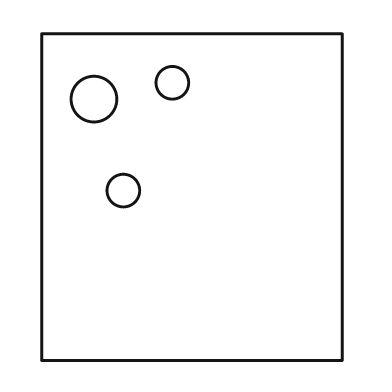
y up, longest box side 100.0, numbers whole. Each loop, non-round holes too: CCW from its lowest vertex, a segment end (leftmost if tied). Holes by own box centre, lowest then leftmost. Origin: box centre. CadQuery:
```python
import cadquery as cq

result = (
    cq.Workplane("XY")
    .moveTo(-46.0, -50.0)
    .lineTo(46.0, -50.0)
    .lineTo(46.0, 50.0)
    .lineTo(-46.0, 50.0)
    .close()
    .moveTo(-21.0, 2.0)
    .circle(5.0)
    .moveTo(-30.0, 30.0)
    .circle(7.0)
    .moveTo(-6.0, 35.0)
    .circle(5.0)
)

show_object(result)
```